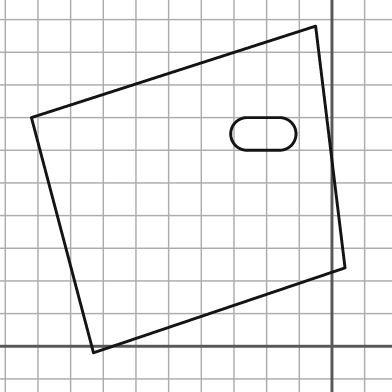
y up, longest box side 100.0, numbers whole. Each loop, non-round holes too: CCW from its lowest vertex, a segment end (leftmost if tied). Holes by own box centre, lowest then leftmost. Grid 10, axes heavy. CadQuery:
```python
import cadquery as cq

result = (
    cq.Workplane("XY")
    .moveTo(-73.0, -2.0)
    .lineTo(4.0, 24.0)
    .lineTo(-5.0, 98.0)
    .lineTo(-92.0, 70.0)
    .close()
    .moveTo(-26.0, 60.0)
    .lineTo(-16.0, 60.0)
    .threePointArc((-11.0, 65.0), (-16.0, 70.0))
    .lineTo(-26.0, 70.0)
    .threePointArc((-31.0, 65.0), (-26.0, 60.0))
    .close()
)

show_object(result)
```